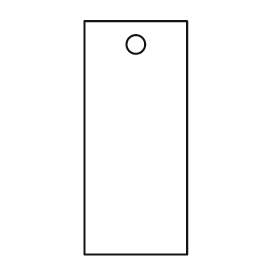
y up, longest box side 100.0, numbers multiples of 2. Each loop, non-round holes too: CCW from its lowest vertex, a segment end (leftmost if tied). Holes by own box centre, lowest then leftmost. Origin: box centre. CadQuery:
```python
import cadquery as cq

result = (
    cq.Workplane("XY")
    .moveTo(-22.0, -50.0)
    .lineTo(22.0, -50.0)
    .lineTo(22.0, 50.0)
    .lineTo(-22.0, 50.0)
    .close()
    .moveTo(0.0, 40.0)
    .circle(4.0)
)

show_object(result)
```